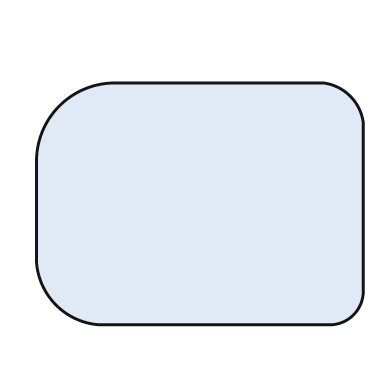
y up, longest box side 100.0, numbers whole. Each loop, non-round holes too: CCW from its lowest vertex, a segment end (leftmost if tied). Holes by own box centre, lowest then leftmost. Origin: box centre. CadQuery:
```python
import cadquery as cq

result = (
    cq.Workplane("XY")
    .moveTo(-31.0, -37.0)
    .lineTo(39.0, -37.0)
    .threePointArc((47.0, -34.0), (50.0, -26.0))
    .lineTo(50.0, 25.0)
    .threePointArc((46.0, 33.0), (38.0, 37.0))
    .lineTo(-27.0, 37.0)
    .threePointArc((-43.0, 30.0), (-50.0, 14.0))
    .lineTo(-50.0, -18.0)
    .threePointArc((-44.0, -31.0), (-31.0, -37.0))
    .close()
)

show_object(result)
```